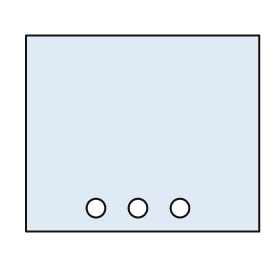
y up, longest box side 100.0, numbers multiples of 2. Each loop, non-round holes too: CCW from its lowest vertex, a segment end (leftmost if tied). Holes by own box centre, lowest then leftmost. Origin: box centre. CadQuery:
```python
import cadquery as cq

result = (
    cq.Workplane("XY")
    .moveTo(-50.0, -42.0)
    .lineTo(50.0, -42.0)
    .lineTo(50.0, 42.0)
    .lineTo(-50.0, 42.0)
    .close()
    .moveTo(-20.0, -32.0)
    .circle(4.0)
    .moveTo(-2.0, -32.0)
    .circle(4.0)
    .moveTo(16.0, -32.0)
    .circle(4.0)
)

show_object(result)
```